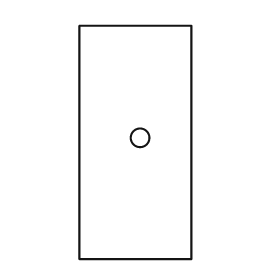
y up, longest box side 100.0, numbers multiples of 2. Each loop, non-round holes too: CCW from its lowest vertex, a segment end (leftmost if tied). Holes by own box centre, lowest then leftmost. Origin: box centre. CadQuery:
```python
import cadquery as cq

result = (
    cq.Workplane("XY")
    .moveTo(-24.0, -50.0)
    .lineTo(24.0, -50.0)
    .lineTo(24.0, 50.0)
    .lineTo(-24.0, 50.0)
    .close()
    .moveTo(2.0, 2.0)
    .circle(4.0)
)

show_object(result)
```